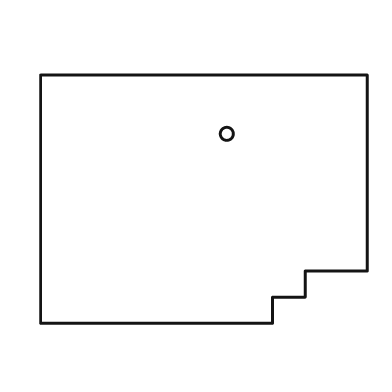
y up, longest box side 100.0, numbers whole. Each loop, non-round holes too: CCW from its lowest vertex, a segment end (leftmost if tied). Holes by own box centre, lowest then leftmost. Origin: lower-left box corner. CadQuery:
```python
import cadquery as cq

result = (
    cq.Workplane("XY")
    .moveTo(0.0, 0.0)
    .lineTo(71.0, 0.0)
    .lineTo(71.0, 8.0)
    .lineTo(81.0, 8.0)
    .lineTo(81.0, 16.0)
    .lineTo(100.0, 16.0)
    .lineTo(100.0, 76.0)
    .lineTo(0.0, 76.0)
    .close()
    .moveTo(57.0, 58.0)
    .circle(2.0)
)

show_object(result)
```